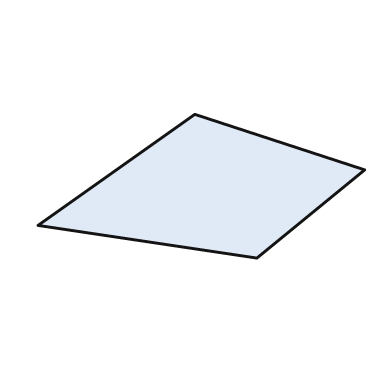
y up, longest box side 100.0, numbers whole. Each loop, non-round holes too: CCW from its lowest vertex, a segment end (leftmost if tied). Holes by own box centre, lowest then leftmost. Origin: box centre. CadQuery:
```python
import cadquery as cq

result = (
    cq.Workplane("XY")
    .moveTo(17.0, -22.0)
    .lineTo(50.0, 5.0)
    .lineTo(-2.0, 22.0)
    .lineTo(-50.0, -12.0)
    .close()
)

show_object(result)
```